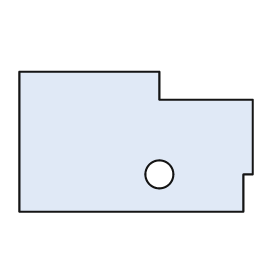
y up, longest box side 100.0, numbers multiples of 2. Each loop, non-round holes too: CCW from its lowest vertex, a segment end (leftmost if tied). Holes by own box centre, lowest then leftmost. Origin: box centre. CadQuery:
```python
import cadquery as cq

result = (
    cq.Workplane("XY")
    .moveTo(-50.0, -30.0)
    .lineTo(46.0, -30.0)
    .lineTo(46.0, -14.0)
    .lineTo(50.0, -14.0)
    .lineTo(50.0, 18.0)
    .lineTo(10.0, 18.0)
    .lineTo(10.0, 30.0)
    .lineTo(-50.0, 30.0)
    .close()
    .moveTo(10.0, -14.0)
    .circle(6.0)
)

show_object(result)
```